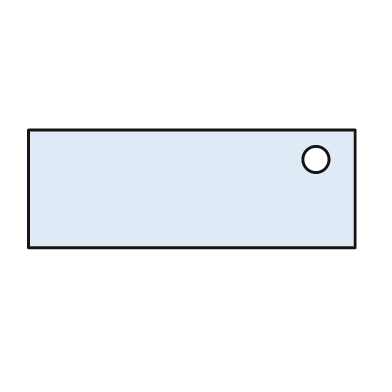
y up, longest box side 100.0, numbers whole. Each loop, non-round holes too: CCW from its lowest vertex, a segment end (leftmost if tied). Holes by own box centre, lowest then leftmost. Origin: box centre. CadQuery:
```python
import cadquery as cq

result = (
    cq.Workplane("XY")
    .moveTo(-50.0, -18.0)
    .lineTo(50.0, -18.0)
    .lineTo(50.0, 18.0)
    .lineTo(-50.0, 18.0)
    .close()
    .moveTo(38.0, 9.0)
    .circle(4.0)
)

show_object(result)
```